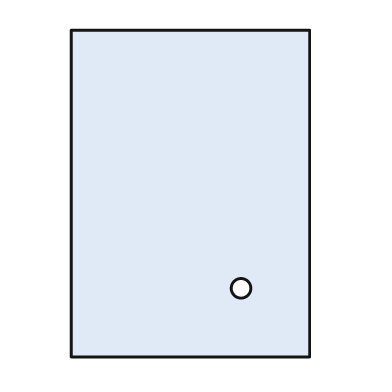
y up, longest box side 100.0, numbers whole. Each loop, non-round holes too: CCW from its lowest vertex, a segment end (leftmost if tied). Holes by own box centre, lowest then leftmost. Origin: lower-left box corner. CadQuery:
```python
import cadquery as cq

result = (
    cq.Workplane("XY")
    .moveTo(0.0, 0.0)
    .lineTo(73.0, 0.0)
    .lineTo(73.0, 100.0)
    .lineTo(0.0, 100.0)
    .close()
    .moveTo(52.0, 21.0)
    .circle(3.0)
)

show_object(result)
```